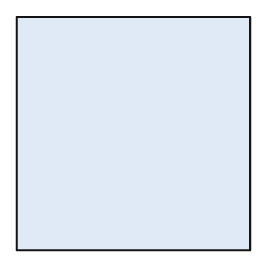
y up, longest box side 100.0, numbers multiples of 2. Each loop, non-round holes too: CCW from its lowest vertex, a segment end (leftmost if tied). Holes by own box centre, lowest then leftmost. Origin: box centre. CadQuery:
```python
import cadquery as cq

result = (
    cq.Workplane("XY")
    .moveTo(-50.0, -50.0)
    .lineTo(50.0, -50.0)
    .lineTo(50.0, 50.0)
    .lineTo(-50.0, 50.0)
    .close()
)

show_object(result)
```